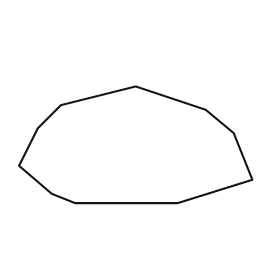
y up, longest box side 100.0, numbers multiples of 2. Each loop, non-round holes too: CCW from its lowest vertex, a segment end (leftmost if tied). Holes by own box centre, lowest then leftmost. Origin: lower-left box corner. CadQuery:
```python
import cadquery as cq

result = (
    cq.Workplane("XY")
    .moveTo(24.0, 0.0)
    .lineTo(68.0, 0.0)
    .lineTo(100.0, 10.0)
    .lineTo(92.0, 30.0)
    .lineTo(80.0, 40.0)
    .lineTo(50.0, 50.0)
    .lineTo(18.0, 42.0)
    .lineTo(8.0, 32.0)
    .lineTo(0.0, 16.0)
    .lineTo(14.0, 4.0)
    .close()
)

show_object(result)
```